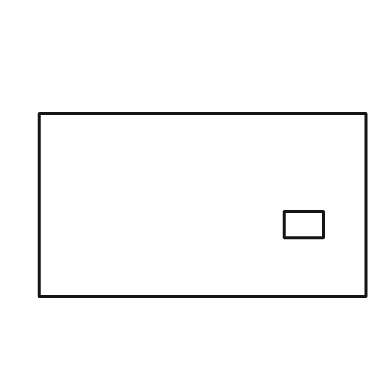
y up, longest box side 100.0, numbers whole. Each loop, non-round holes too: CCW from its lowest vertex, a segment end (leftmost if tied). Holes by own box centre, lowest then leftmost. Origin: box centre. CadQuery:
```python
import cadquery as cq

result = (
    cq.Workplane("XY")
    .moveTo(-50.0, -28.0)
    .lineTo(50.0, -28.0)
    .lineTo(50.0, 28.0)
    .lineTo(-50.0, 28.0)
    .close()
    .moveTo(25.0, -10.0)
    .lineTo(37.0, -10.0)
    .lineTo(37.0, -2.0)
    .lineTo(25.0, -2.0)
    .close()
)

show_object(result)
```